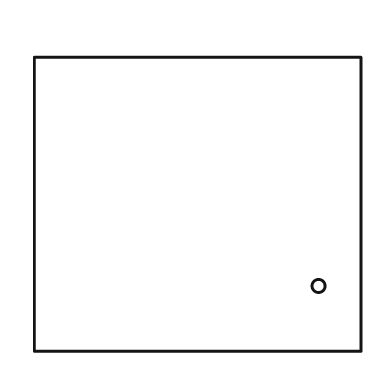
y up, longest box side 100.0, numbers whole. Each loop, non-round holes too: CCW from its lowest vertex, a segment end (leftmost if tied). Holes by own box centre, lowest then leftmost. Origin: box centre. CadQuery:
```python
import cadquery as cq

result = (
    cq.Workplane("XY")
    .moveTo(-50.0, -45.0)
    .lineTo(50.0, -45.0)
    .lineTo(50.0, 45.0)
    .lineTo(-50.0, 45.0)
    .close()
    .moveTo(37.0, -25.0)
    .circle(2.0)
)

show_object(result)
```